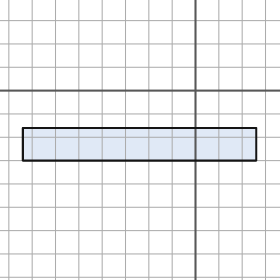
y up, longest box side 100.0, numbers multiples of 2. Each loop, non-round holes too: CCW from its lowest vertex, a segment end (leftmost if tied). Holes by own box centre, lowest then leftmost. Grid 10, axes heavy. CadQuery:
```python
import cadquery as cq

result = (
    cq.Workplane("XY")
    .moveTo(-74.0, -30.0)
    .lineTo(26.0, -30.0)
    .lineTo(26.0, -16.0)
    .lineTo(-74.0, -16.0)
    .close()
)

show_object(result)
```